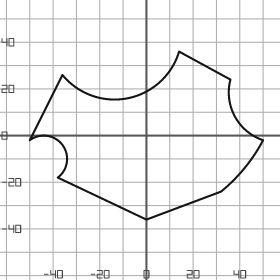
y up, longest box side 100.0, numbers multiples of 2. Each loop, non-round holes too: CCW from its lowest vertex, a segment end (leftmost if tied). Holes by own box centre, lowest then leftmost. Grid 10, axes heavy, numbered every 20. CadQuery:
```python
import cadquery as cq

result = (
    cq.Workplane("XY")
    .moveTo(0.0, -36.0)
    .lineTo(32.0, -24.0)
    .threePointArc((42.0, -14.0), (50.0, -2.0))
    .threePointArc((38.0, 8.0), (36.0, 24.0))
    .lineTo(14.0, 36.0)
    .threePointArc((-8.0, 16.0), (-36.0, 26.0))
    .lineTo(-50.0, -2.0)
    .threePointArc((-36.0, -4.0), (-38.0, -18.0))
    .close()
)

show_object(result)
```